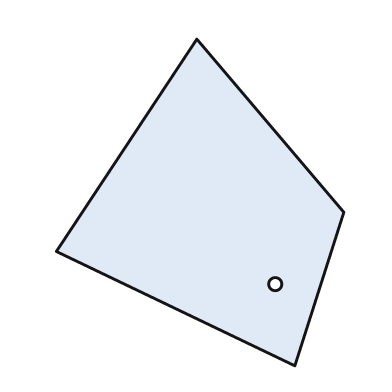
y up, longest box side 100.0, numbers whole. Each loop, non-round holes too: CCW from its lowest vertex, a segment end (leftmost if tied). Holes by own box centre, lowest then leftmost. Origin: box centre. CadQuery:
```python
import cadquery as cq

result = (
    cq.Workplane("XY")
    .moveTo(29.0, -50.0)
    .lineTo(44.0, -3.0)
    .lineTo(-1.0, 50.0)
    .lineTo(-44.0, -15.0)
    .close()
    .moveTo(23.0, -25.0)
    .circle(2.0)
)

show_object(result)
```